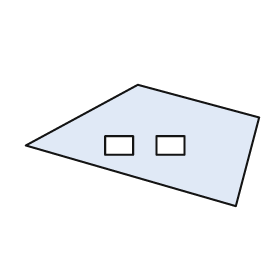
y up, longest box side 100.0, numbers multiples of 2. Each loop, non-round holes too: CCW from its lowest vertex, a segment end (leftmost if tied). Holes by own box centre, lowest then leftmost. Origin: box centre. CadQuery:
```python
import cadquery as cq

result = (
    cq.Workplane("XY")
    .moveTo(40.0, -26.0)
    .lineTo(50.0, 12.0)
    .lineTo(-2.0, 26.0)
    .lineTo(-50.0, 0.0)
    .close()
    .moveTo(-16.0, -4.0)
    .lineTo(-4.0, -4.0)
    .lineTo(-4.0, 4.0)
    .lineTo(-16.0, 4.0)
    .close()
    .moveTo(6.0, -4.0)
    .lineTo(18.0, -4.0)
    .lineTo(18.0, 4.0)
    .lineTo(6.0, 4.0)
    .close()
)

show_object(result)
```